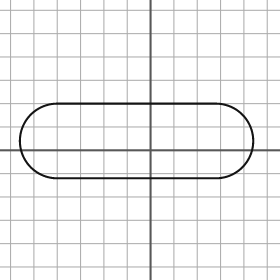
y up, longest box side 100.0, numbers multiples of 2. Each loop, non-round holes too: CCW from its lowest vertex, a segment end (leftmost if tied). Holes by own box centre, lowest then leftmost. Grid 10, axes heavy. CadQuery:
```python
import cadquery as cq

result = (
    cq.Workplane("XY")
    .moveTo(-40.0, -12.0)
    .lineTo(28.0, -12.0)
    .threePointArc((44.0, 4.0), (28.0, 20.0))
    .lineTo(-40.0, 20.0)
    .threePointArc((-56.0, 4.0), (-40.0, -12.0))
    .close()
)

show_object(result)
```